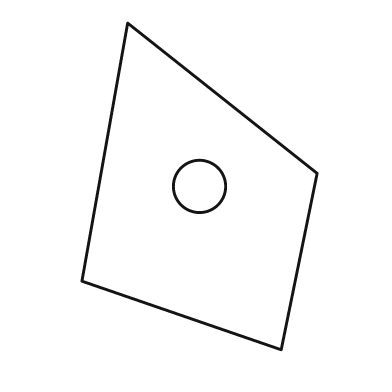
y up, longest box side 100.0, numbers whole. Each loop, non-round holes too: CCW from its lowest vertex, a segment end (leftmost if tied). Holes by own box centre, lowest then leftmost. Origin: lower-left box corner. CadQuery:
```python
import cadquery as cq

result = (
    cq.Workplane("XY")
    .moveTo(61.0, 0.0)
    .lineTo(72.0, 54.0)
    .lineTo(14.0, 100.0)
    .lineTo(0.0, 21.0)
    .close()
    .moveTo(36.0, 50.0)
    .circle(8.0)
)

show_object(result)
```